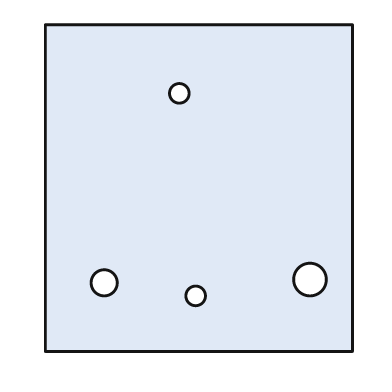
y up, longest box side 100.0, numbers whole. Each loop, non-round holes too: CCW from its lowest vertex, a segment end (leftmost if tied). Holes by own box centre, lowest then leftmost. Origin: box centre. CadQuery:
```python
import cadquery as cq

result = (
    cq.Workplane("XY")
    .moveTo(-47.0, -50.0)
    .lineTo(47.0, -50.0)
    .lineTo(47.0, 50.0)
    .lineTo(-47.0, 50.0)
    .close()
    .moveTo(-1.0, -33.0)
    .circle(3.0)
    .moveTo(-29.0, -29.0)
    .circle(4.0)
    .moveTo(34.0, -28.0)
    .circle(5.0)
    .moveTo(-6.0, 29.0)
    .circle(3.0)
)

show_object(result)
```